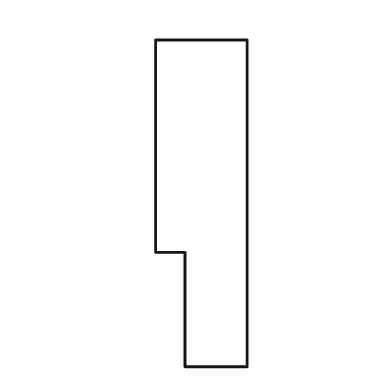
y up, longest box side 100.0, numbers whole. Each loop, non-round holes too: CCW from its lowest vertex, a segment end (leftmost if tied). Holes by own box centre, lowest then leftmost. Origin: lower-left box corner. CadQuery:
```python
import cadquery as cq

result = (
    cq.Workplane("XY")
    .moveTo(9.0, 0.0)
    .lineTo(28.0, 0.0)
    .lineTo(28.0, 100.0)
    .lineTo(0.0, 100.0)
    .lineTo(0.0, 35.0)
    .lineTo(9.0, 35.0)
    .close()
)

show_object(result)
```